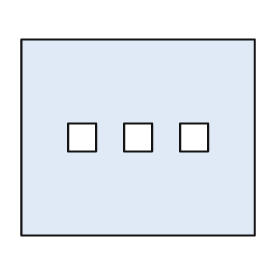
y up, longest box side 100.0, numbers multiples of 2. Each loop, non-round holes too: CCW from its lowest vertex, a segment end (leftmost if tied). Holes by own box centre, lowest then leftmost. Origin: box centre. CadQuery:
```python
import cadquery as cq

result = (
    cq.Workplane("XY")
    .moveTo(-50.0, -42.0)
    .lineTo(50.0, -42.0)
    .lineTo(50.0, 42.0)
    .lineTo(-50.0, 42.0)
    .close()
    .moveTo(-30.0, -6.0)
    .lineTo(-18.0, -6.0)
    .lineTo(-18.0, 6.0)
    .lineTo(-30.0, 6.0)
    .close()
    .moveTo(-6.0, -6.0)
    .lineTo(6.0, -6.0)
    .lineTo(6.0, 6.0)
    .lineTo(-6.0, 6.0)
    .close()
    .moveTo(18.0, -6.0)
    .lineTo(30.0, -6.0)
    .lineTo(30.0, 6.0)
    .lineTo(18.0, 6.0)
    .close()
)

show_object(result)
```